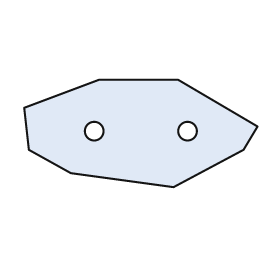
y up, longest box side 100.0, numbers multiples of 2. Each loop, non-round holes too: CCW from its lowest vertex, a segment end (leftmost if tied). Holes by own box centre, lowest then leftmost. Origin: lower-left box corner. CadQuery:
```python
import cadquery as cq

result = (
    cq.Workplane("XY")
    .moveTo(64.0, 0.0)
    .lineTo(94.0, 16.0)
    .lineTo(100.0, 26.0)
    .lineTo(66.0, 46.0)
    .lineTo(32.0, 46.0)
    .lineTo(0.0, 34.0)
    .lineTo(2.0, 16.0)
    .lineTo(20.0, 6.0)
    .close()
    .moveTo(30.0, 24.0)
    .circle(4.0)
    .moveTo(70.0, 24.0)
    .circle(4.0)
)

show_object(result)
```